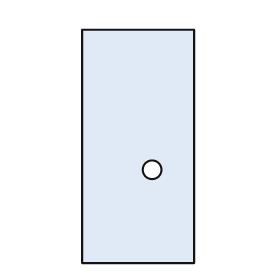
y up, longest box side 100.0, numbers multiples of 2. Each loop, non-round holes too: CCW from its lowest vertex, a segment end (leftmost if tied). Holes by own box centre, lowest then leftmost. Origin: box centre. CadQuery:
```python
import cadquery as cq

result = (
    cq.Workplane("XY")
    .moveTo(-24.0, -50.0)
    .lineTo(24.0, -50.0)
    .lineTo(24.0, 50.0)
    .lineTo(-24.0, 50.0)
    .close()
    .moveTo(6.0, -10.0)
    .circle(4.0)
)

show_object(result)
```